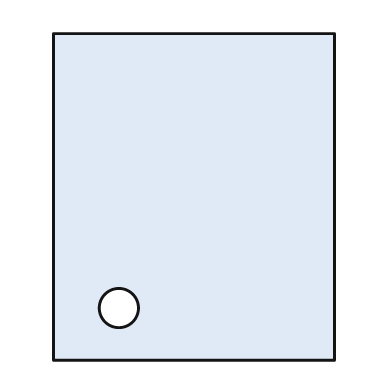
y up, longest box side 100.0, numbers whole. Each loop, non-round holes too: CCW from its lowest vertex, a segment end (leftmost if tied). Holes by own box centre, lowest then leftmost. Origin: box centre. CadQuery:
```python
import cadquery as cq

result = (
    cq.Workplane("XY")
    .moveTo(-43.0, -50.0)
    .lineTo(43.0, -50.0)
    .lineTo(43.0, 50.0)
    .lineTo(-43.0, 50.0)
    .close()
    .moveTo(-23.0, -34.0)
    .circle(6.0)
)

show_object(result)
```